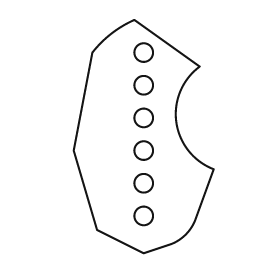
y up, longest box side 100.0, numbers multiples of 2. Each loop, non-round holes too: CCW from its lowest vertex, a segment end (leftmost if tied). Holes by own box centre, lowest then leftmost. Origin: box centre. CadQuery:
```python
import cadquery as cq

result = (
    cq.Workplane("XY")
    .moveTo(0.0, -50.0)
    .lineTo(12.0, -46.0)
    .threePointArc((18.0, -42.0), (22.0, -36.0))
    .lineTo(30.0, -14.0)
    .threePointArc((14.0, 6.0), (24.0, 30.0))
    .lineTo(-4.0, 50.0)
    .threePointArc((-14.0, 44.0), (-22.0, 36.0))
    .lineTo(-30.0, -6.0)
    .lineTo(-20.0, -40.0)
    .close()
    .moveTo(0.0, -34.0)
    .circle(4.0)
    .moveTo(0.0, -20.0)
    .circle(4.0)
    .moveTo(0.0, -6.0)
    .circle(4.0)
    .moveTo(0.0, 8.0)
    .circle(4.0)
    .moveTo(0.0, 22.0)
    .circle(4.0)
    .moveTo(0.0, 36.0)
    .circle(4.0)
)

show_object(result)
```